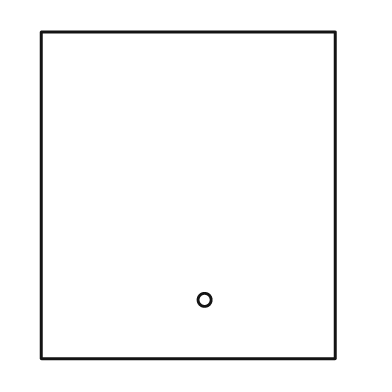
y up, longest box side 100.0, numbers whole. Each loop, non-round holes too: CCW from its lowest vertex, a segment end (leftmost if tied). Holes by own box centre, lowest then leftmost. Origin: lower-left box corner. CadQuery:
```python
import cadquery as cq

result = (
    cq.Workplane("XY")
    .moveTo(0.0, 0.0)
    .lineTo(90.0, 0.0)
    .lineTo(90.0, 100.0)
    .lineTo(0.0, 100.0)
    .close()
    .moveTo(50.0, 18.0)
    .circle(2.0)
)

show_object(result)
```